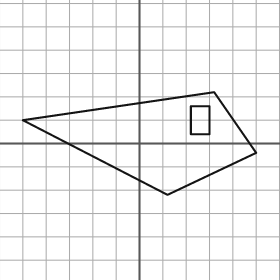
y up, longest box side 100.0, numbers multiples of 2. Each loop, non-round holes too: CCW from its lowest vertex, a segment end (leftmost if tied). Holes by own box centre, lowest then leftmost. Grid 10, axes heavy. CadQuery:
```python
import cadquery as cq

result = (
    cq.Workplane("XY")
    .moveTo(12.0, -22.0)
    .lineTo(50.0, -4.0)
    .lineTo(32.0, 22.0)
    .lineTo(-50.0, 10.0)
    .close()
    .moveTo(22.0, 4.0)
    .lineTo(30.0, 4.0)
    .lineTo(30.0, 16.0)
    .lineTo(22.0, 16.0)
    .close()
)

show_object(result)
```